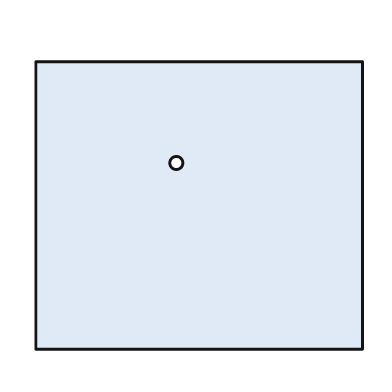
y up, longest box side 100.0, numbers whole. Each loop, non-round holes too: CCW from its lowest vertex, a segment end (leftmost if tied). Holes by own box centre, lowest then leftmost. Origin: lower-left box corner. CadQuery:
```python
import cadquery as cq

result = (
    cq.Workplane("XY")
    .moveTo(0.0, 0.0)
    .lineTo(100.0, 0.0)
    .lineTo(100.0, 88.0)
    .lineTo(0.0, 88.0)
    .close()
    .moveTo(43.0, 57.0)
    .circle(2.0)
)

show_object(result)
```